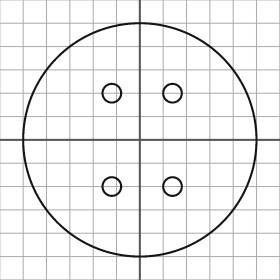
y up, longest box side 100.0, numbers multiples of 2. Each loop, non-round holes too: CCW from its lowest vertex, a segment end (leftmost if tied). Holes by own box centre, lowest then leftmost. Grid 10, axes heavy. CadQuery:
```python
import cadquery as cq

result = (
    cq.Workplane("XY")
    .moveTo(0.0, 0.0)
    .circle(50.0)
    .moveTo(-12.0, -20.0)
    .circle(4.0)
    .moveTo(14.0, -20.0)
    .circle(4.0)
    .moveTo(-12.0, 20.0)
    .circle(4.0)
    .moveTo(14.0, 20.0)
    .circle(4.0)
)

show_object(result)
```